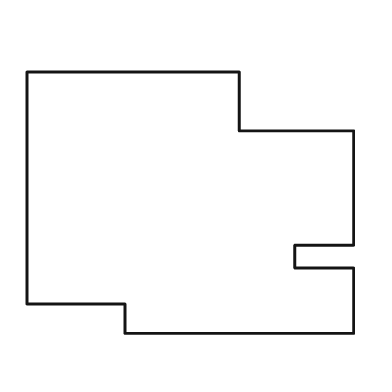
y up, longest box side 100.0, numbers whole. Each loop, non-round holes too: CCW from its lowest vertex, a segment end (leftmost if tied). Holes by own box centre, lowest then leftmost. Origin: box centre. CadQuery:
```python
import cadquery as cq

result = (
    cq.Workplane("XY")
    .moveTo(-20.0, -40.0)
    .lineTo(50.0, -40.0)
    .lineTo(50.0, -20.0)
    .lineTo(32.0, -20.0)
    .lineTo(32.0, -13.0)
    .lineTo(50.0, -13.0)
    .lineTo(50.0, 22.0)
    .lineTo(15.0, 22.0)
    .lineTo(15.0, 40.0)
    .lineTo(-50.0, 40.0)
    .lineTo(-50.0, -31.0)
    .lineTo(-20.0, -31.0)
    .close()
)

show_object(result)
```